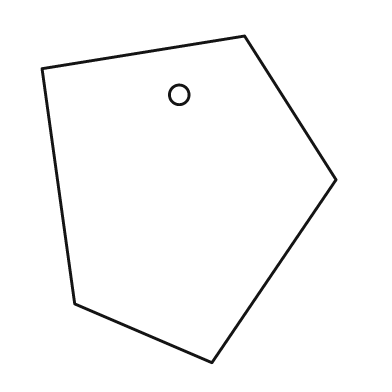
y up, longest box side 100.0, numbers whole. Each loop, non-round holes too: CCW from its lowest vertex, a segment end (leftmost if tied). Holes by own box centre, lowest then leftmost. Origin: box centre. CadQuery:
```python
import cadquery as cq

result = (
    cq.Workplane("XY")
    .moveTo(7.0, -50.0)
    .lineTo(45.0, 6.0)
    .lineTo(17.0, 50.0)
    .lineTo(-45.0, 40.0)
    .lineTo(-35.0, -32.0)
    .close()
    .moveTo(-3.0, 32.0)
    .circle(3.0)
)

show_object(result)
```